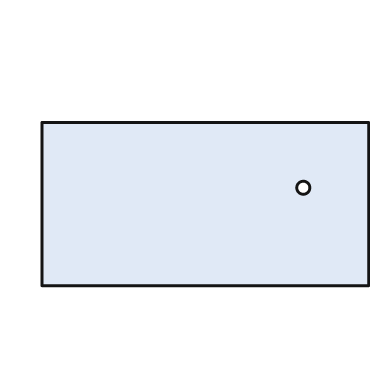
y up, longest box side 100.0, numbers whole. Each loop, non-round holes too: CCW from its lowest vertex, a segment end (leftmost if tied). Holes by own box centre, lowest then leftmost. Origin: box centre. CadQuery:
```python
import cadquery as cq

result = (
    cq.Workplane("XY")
    .moveTo(-50.0, -25.0)
    .lineTo(50.0, -25.0)
    .lineTo(50.0, 25.0)
    .lineTo(-50.0, 25.0)
    .close()
    .moveTo(30.0, 5.0)
    .circle(2.0)
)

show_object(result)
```